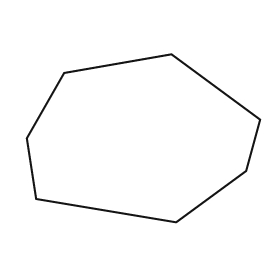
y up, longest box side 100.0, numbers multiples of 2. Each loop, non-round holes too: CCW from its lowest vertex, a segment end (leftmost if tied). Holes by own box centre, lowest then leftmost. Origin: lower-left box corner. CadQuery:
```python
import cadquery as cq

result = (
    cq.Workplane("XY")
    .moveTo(64.0, 0.0)
    .lineTo(94.0, 22.0)
    .lineTo(100.0, 44.0)
    .lineTo(62.0, 72.0)
    .lineTo(16.0, 64.0)
    .lineTo(0.0, 36.0)
    .lineTo(4.0, 10.0)
    .close()
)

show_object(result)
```